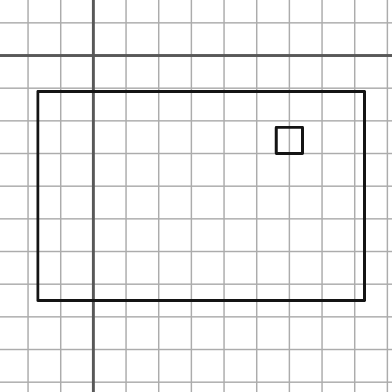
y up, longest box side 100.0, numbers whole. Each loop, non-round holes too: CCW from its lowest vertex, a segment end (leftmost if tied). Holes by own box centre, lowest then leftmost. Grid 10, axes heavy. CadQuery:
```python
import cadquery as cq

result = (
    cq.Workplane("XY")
    .moveTo(-17.0, -75.0)
    .lineTo(83.0, -75.0)
    .lineTo(83.0, -11.0)
    .lineTo(-17.0, -11.0)
    .close()
    .moveTo(56.0, -30.0)
    .lineTo(64.0, -30.0)
    .lineTo(64.0, -22.0)
    .lineTo(56.0, -22.0)
    .close()
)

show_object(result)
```